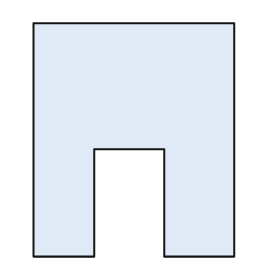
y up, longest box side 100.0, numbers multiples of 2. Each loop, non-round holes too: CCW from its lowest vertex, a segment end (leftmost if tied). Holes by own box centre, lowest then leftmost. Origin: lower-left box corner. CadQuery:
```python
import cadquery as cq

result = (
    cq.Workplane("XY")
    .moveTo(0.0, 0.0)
    .lineTo(26.0, 0.0)
    .lineTo(26.0, 46.0)
    .lineTo(56.0, 46.0)
    .lineTo(56.0, 0.0)
    .lineTo(86.0, 0.0)
    .lineTo(86.0, 100.0)
    .lineTo(0.0, 100.0)
    .close()
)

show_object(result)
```